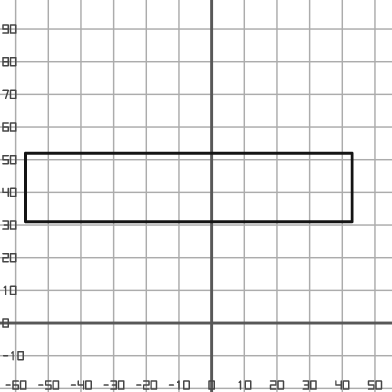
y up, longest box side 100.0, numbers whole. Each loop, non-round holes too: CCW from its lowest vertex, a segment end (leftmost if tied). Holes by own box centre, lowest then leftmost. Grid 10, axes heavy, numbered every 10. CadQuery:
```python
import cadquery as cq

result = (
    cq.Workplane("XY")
    .moveTo(-57.0, 31.0)
    .lineTo(43.0, 31.0)
    .lineTo(43.0, 52.0)
    .lineTo(-57.0, 52.0)
    .close()
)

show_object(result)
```